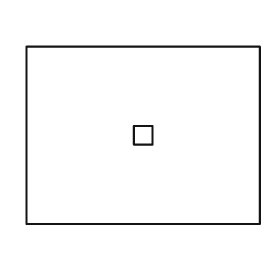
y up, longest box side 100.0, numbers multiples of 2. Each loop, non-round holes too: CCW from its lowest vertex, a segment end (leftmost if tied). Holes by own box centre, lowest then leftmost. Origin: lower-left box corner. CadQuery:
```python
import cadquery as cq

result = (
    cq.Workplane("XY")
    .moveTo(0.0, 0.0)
    .lineTo(100.0, 0.0)
    .lineTo(100.0, 76.0)
    .lineTo(0.0, 76.0)
    .close()
    .moveTo(46.0, 34.0)
    .lineTo(54.0, 34.0)
    .lineTo(54.0, 42.0)
    .lineTo(46.0, 42.0)
    .close()
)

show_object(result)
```